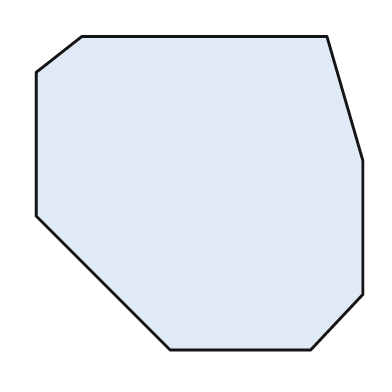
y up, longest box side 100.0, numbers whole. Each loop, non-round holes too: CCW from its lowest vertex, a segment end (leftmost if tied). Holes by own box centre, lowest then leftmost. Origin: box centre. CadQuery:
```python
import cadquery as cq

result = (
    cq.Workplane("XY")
    .moveTo(-9.0, -48.0)
    .lineTo(34.0, -48.0)
    .lineTo(50.0, -31.0)
    .lineTo(50.0, 10.0)
    .lineTo(39.0, 48.0)
    .lineTo(-36.0, 48.0)
    .lineTo(-50.0, 37.0)
    .lineTo(-50.0, -7.0)
    .close()
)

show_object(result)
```